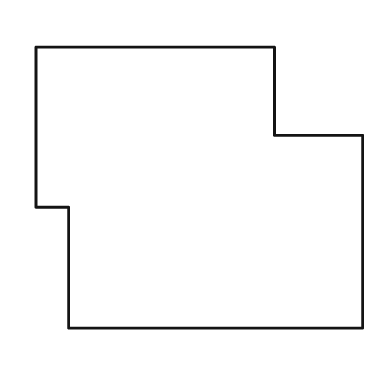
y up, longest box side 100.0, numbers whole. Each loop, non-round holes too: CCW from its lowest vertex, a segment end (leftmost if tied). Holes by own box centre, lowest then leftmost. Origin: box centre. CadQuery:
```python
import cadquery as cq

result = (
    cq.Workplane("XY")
    .moveTo(-40.0, -43.0)
    .lineTo(50.0, -43.0)
    .lineTo(50.0, 16.0)
    .lineTo(23.0, 16.0)
    .lineTo(23.0, 43.0)
    .lineTo(-50.0, 43.0)
    .lineTo(-50.0, -6.0)
    .lineTo(-40.0, -6.0)
    .close()
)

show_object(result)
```